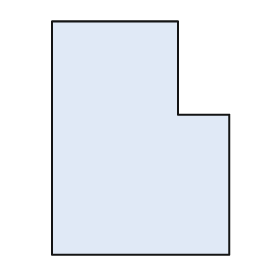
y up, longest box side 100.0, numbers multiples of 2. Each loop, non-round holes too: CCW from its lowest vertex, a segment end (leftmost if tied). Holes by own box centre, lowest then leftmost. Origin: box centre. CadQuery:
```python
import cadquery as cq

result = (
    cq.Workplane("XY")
    .moveTo(-38.0, -50.0)
    .lineTo(38.0, -50.0)
    .lineTo(38.0, 10.0)
    .lineTo(16.0, 10.0)
    .lineTo(16.0, 50.0)
    .lineTo(-38.0, 50.0)
    .close()
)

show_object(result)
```